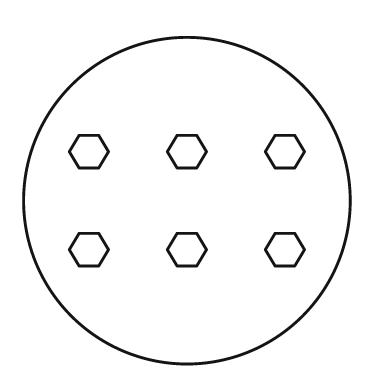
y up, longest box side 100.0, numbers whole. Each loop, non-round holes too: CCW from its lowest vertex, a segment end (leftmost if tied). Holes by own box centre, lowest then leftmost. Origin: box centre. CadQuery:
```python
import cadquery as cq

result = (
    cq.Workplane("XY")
    .moveTo(0.0, 0.0)
    .circle(50.0)
    .moveTo(-33.0, -20.0)
    .lineTo(-27.0, -20.0)
    .lineTo(-24.0, -15.0)
    .lineTo(-27.0, -10.0)
    .lineTo(-33.0, -10.0)
    .lineTo(-36.0, -15.0)
    .close()
    .moveTo(-3.0, -20.0)
    .lineTo(3.0, -20.0)
    .lineTo(6.0, -15.0)
    .lineTo(3.0, -10.0)
    .lineTo(-3.0, -10.0)
    .lineTo(-6.0, -15.0)
    .close()
    .moveTo(27.0, -20.0)
    .lineTo(33.0, -20.0)
    .lineTo(36.0, -15.0)
    .lineTo(33.0, -10.0)
    .lineTo(27.0, -10.0)
    .lineTo(24.0, -15.0)
    .close()
    .moveTo(-33.0, 10.0)
    .lineTo(-27.0, 10.0)
    .lineTo(-24.0, 15.0)
    .lineTo(-27.0, 20.0)
    .lineTo(-33.0, 20.0)
    .lineTo(-36.0, 15.0)
    .close()
    .moveTo(-3.0, 10.0)
    .lineTo(3.0, 10.0)
    .lineTo(6.0, 15.0)
    .lineTo(3.0, 20.0)
    .lineTo(-3.0, 20.0)
    .lineTo(-6.0, 15.0)
    .close()
    .moveTo(27.0, 10.0)
    .lineTo(33.0, 10.0)
    .lineTo(36.0, 15.0)
    .lineTo(33.0, 20.0)
    .lineTo(27.0, 20.0)
    .lineTo(24.0, 15.0)
    .close()
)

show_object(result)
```